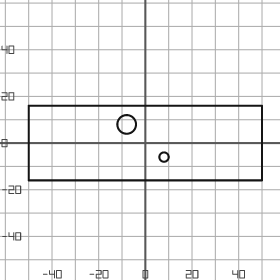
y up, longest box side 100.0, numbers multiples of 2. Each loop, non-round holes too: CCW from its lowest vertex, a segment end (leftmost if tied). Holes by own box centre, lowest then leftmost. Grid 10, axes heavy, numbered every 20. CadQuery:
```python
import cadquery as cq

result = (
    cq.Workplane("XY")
    .moveTo(-50.0, -16.0)
    .lineTo(50.0, -16.0)
    .lineTo(50.0, 16.0)
    .lineTo(-50.0, 16.0)
    .close()
    .moveTo(8.0, -6.0)
    .circle(2.0)
    .moveTo(-8.0, 8.0)
    .circle(4.0)
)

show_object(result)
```